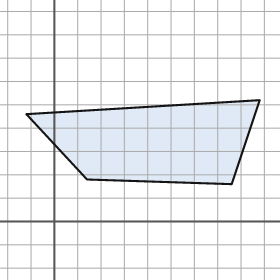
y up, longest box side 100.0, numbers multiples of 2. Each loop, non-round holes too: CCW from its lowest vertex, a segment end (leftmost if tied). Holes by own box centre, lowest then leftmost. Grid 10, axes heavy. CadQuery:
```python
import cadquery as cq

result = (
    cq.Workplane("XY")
    .moveTo(76.0, 16.0)
    .lineTo(88.0, 52.0)
    .lineTo(-12.0, 46.0)
    .lineTo(14.0, 18.0)
    .close()
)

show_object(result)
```